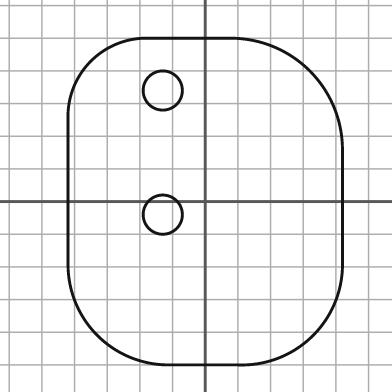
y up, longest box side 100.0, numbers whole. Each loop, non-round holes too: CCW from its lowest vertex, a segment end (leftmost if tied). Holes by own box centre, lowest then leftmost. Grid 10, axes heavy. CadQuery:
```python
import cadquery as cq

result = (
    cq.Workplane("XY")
    .moveTo(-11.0, -50.0)
    .lineTo(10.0, -50.0)
    .threePointArc((33.0, -41.0), (42.0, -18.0))
    .lineTo(42.0, 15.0)
    .threePointArc((32.0, 40.0), (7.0, 50.0))
    .lineTo(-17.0, 50.0)
    .threePointArc((-35.0, 43.0), (-42.0, 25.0))
    .lineTo(-42.0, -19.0)
    .threePointArc((-33.0, -41.0), (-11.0, -50.0))
    .close()
    .moveTo(-13.0, -4.0)
    .circle(6.0)
    .moveTo(-13.0, 34.0)
    .circle(6.0)
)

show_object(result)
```